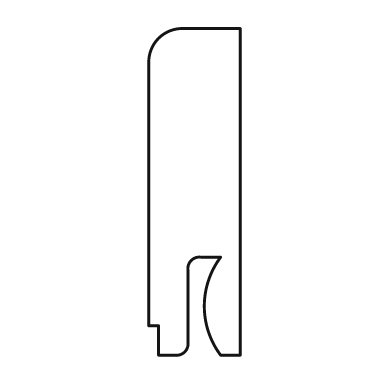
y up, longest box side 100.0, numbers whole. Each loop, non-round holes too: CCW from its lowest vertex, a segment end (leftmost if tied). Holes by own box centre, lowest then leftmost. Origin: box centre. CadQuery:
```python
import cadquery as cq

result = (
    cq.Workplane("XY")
    .moveTo(-11.0, -50.0)
    .lineTo(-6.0, -50.0)
    .threePointArc((-3.0, -49.0), (-2.0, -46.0))
    .lineTo(-2.0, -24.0)
    .threePointArc((-1.0, -21.0), (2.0, -20.0))
    .lineTo(8.0, -20.0)
    .threePointArc((3.0, -35.0), (8.0, -50.0))
    .lineTo(14.0, -50.0)
    .lineTo(14.0, 50.0)
    .lineTo(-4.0, 50.0)
    .threePointArc((-11.0, 47.0), (-14.0, 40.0))
    .lineTo(-14.0, -41.0)
    .lineTo(-11.0, -41.0)
    .close()
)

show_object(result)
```